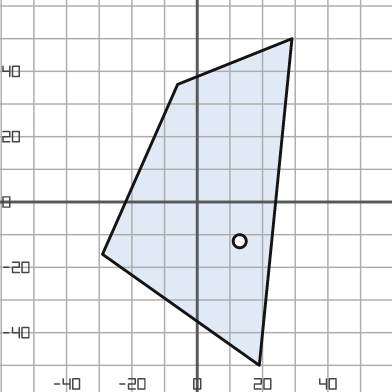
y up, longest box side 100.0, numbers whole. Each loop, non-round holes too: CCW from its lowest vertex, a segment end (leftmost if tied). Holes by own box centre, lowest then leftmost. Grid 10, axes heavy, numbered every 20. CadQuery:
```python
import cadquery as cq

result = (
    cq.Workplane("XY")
    .moveTo(19.0, -50.0)
    .lineTo(29.0, 50.0)
    .lineTo(-6.0, 36.0)
    .lineTo(-29.0, -16.0)
    .close()
    .moveTo(13.0, -12.0)
    .circle(2.0)
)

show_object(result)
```